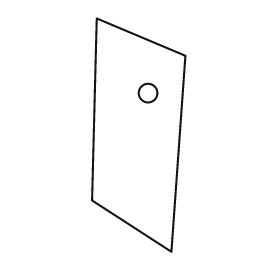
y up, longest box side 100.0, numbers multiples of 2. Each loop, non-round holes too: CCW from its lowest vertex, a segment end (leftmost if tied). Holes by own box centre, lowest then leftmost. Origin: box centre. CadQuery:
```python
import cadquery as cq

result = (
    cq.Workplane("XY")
    .moveTo(14.0, -50.0)
    .lineTo(20.0, 34.0)
    .lineTo(-18.0, 50.0)
    .lineTo(-20.0, -28.0)
    .close()
    .moveTo(4.0, 18.0)
    .circle(4.0)
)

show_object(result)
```